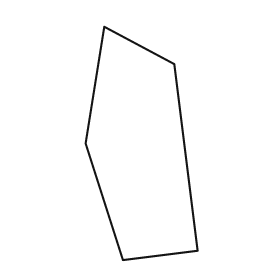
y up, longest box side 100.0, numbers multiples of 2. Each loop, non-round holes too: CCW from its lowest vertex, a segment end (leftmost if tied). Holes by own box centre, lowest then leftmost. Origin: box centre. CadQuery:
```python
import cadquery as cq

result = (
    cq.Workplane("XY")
    .moveTo(-8.0, -50.0)
    .lineTo(24.0, -46.0)
    .lineTo(14.0, 34.0)
    .lineTo(-16.0, 50.0)
    .lineTo(-24.0, 0.0)
    .close()
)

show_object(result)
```